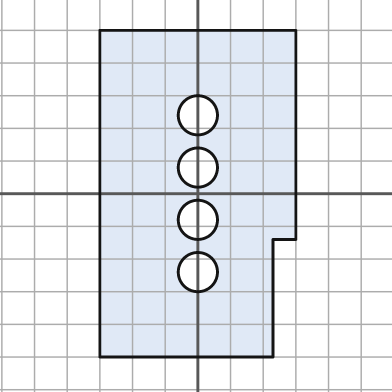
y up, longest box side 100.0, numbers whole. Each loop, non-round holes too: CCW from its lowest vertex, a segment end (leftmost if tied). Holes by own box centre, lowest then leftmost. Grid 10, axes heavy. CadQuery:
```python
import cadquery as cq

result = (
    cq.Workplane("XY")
    .moveTo(-30.0, -50.0)
    .lineTo(23.0, -50.0)
    .lineTo(23.0, -14.0)
    .lineTo(30.0, -14.0)
    .lineTo(30.0, 50.0)
    .lineTo(-30.0, 50.0)
    .close()
    .moveTo(0.0, -24.0)
    .circle(6.0)
    .moveTo(0.0, -8.0)
    .circle(6.0)
    .moveTo(0.0, 8.0)
    .circle(6.0)
    .moveTo(0.0, 24.0)
    .circle(6.0)
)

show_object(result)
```